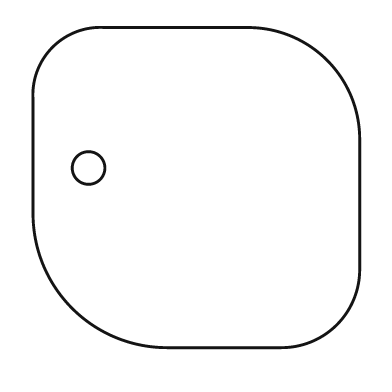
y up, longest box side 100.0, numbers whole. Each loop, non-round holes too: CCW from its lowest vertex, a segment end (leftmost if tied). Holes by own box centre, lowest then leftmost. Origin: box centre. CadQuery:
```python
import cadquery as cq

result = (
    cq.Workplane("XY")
    .moveTo(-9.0, -49.0)
    .lineTo(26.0, -49.0)
    .threePointArc((43.0, -42.0), (50.0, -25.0))
    .lineTo(50.0, 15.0)
    .threePointArc((40.0, 39.0), (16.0, 49.0))
    .lineTo(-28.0, 49.0)
    .threePointArc((-44.0, 43.0), (-50.0, 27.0))
    .lineTo(-50.0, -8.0)
    .threePointArc((-38.0, -37.0), (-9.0, -49.0))
    .close()
    .moveTo(-33.0, 6.0)
    .circle(5.0)
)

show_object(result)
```